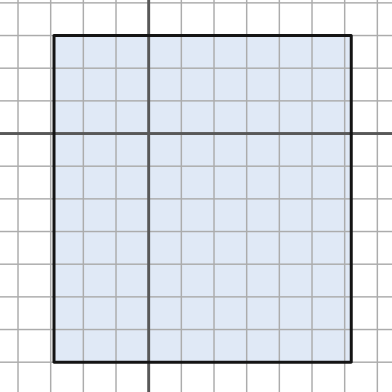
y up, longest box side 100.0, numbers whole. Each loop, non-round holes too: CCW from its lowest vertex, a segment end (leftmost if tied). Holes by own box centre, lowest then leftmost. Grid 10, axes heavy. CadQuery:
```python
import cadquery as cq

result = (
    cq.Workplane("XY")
    .moveTo(-29.0, -70.0)
    .lineTo(62.0, -70.0)
    .lineTo(62.0, 30.0)
    .lineTo(-29.0, 30.0)
    .close()
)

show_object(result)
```